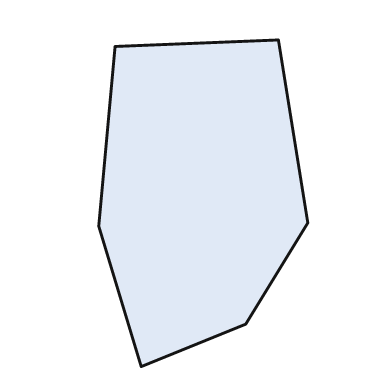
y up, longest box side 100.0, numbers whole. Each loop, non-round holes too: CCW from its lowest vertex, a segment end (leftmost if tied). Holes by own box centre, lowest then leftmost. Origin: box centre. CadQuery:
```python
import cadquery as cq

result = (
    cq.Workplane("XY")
    .moveTo(-19.0, -50.0)
    .lineTo(13.0, -37.0)
    .lineTo(32.0, -6.0)
    .lineTo(23.0, 50.0)
    .lineTo(-27.0, 48.0)
    .lineTo(-32.0, -7.0)
    .close()
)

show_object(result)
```